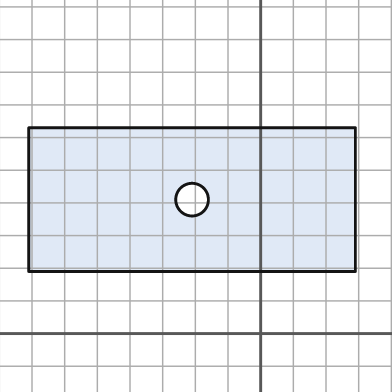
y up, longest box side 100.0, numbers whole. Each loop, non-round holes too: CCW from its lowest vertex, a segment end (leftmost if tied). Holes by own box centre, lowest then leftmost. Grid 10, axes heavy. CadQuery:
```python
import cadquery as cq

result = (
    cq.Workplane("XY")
    .moveTo(-71.0, 19.0)
    .lineTo(29.0, 19.0)
    .lineTo(29.0, 63.0)
    .lineTo(-71.0, 63.0)
    .close()
    .moveTo(-21.0, 41.0)
    .circle(5.0)
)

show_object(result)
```